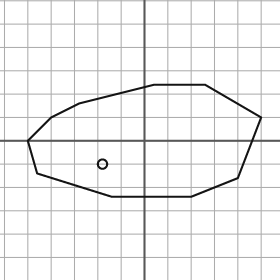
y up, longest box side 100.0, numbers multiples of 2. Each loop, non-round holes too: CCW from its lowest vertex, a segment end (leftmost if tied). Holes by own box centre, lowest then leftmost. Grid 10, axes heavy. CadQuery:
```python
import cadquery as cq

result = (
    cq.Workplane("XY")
    .moveTo(-14.0, -24.0)
    .lineTo(20.0, -24.0)
    .lineTo(40.0, -16.0)
    .lineTo(50.0, 10.0)
    .lineTo(26.0, 24.0)
    .lineTo(4.0, 24.0)
    .lineTo(-28.0, 16.0)
    .lineTo(-40.0, 10.0)
    .lineTo(-50.0, 0.0)
    .lineTo(-46.0, -14.0)
    .close()
    .moveTo(-18.0, -10.0)
    .circle(2.0)
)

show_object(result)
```